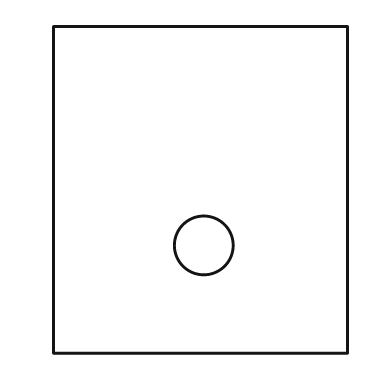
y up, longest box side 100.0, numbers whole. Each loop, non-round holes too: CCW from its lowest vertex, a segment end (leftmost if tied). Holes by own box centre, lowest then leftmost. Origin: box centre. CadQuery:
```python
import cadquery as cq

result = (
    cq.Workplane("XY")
    .moveTo(-45.0, -50.0)
    .lineTo(45.0, -50.0)
    .lineTo(45.0, 50.0)
    .lineTo(-45.0, 50.0)
    .close()
    .moveTo(1.0, -17.0)
    .circle(9.0)
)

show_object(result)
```